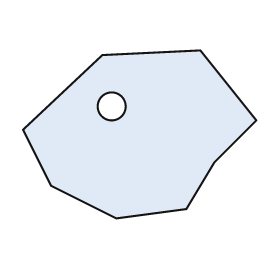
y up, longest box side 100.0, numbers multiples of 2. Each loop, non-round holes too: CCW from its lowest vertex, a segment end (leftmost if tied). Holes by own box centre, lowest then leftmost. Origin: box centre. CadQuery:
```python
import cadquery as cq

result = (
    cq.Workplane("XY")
    .moveTo(-10.0, -36.0)
    .lineTo(20.0, -32.0)
    .lineTo(32.0, -12.0)
    .lineTo(50.0, 6.0)
    .lineTo(26.0, 36.0)
    .lineTo(-16.0, 34.0)
    .lineTo(-50.0, 2.0)
    .lineTo(-38.0, -22.0)
    .close()
    .moveTo(-12.0, 12.0)
    .circle(6.0)
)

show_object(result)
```